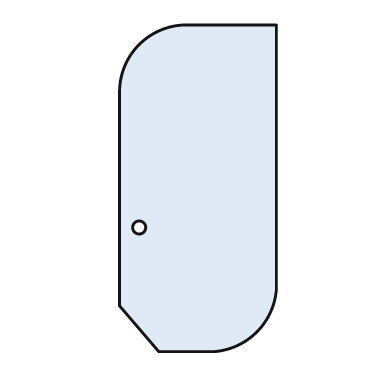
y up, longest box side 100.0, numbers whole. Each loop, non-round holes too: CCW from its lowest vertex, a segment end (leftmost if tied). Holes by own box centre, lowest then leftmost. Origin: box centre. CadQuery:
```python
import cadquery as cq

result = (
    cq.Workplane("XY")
    .moveTo(-12.0, -50.0)
    .lineTo(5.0, -50.0)
    .threePointArc((18.0, -44.0), (24.0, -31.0))
    .lineTo(24.0, 50.0)
    .lineTo(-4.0, 50.0)
    .threePointArc((-18.0, 44.0), (-24.0, 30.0))
    .lineTo(-24.0, -36.0)
    .close()
    .moveTo(-18.0, -12.0)
    .circle(2.0)
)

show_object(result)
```